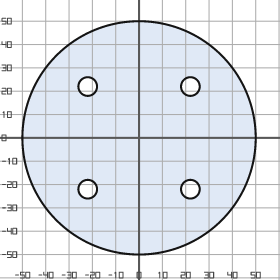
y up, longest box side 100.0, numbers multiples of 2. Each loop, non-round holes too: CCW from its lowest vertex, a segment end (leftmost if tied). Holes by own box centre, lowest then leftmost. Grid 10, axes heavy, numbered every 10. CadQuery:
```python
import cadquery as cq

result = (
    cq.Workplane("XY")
    .moveTo(0.0, 0.0)
    .circle(50.0)
    .moveTo(-22.0, -22.0)
    .circle(4.0)
    .moveTo(22.0, -22.0)
    .circle(4.0)
    .moveTo(-22.0, 22.0)
    .circle(4.0)
    .moveTo(22.0, 22.0)
    .circle(4.0)
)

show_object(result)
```